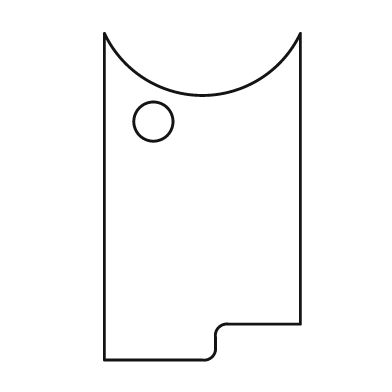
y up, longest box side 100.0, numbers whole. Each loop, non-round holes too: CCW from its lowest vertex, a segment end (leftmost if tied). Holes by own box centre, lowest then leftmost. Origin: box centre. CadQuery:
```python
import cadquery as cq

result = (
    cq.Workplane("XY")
    .moveTo(-30.0, -50.0)
    .lineTo(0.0, -50.0)
    .threePointArc((3.0, -49.0), (4.0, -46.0))
    .lineTo(4.0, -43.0)
    .threePointArc((5.0, -40.0), (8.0, -39.0))
    .lineTo(30.0, -39.0)
    .lineTo(30.0, 50.0)
    .threePointArc((0.0, 31.0), (-30.0, 50.0))
    .close()
    .moveTo(-15.0, 23.0)
    .circle(6.0)
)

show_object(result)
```